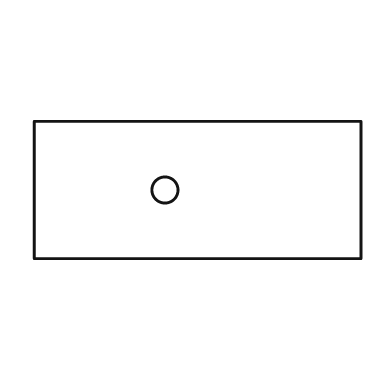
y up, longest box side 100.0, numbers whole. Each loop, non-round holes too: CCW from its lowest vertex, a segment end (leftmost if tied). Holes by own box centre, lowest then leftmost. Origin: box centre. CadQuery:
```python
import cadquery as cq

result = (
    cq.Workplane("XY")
    .moveTo(-50.0, -21.0)
    .lineTo(50.0, -21.0)
    .lineTo(50.0, 21.0)
    .lineTo(-50.0, 21.0)
    .close()
    .moveTo(-10.0, 0.0)
    .circle(4.0)
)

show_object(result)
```